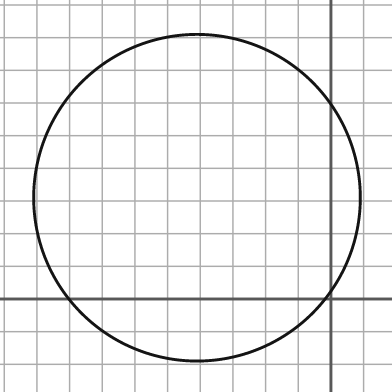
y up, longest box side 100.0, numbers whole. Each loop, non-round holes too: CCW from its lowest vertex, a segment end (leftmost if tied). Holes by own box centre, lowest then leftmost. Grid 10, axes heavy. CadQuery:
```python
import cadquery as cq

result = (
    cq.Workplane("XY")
    .moveTo(-41.0, 31.0)
    .circle(50.0)
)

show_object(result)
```